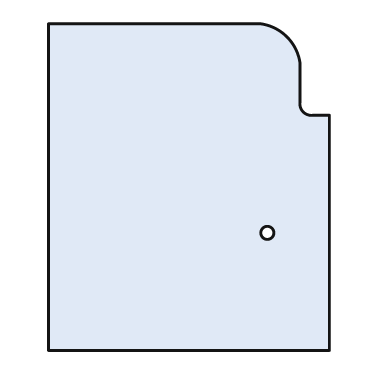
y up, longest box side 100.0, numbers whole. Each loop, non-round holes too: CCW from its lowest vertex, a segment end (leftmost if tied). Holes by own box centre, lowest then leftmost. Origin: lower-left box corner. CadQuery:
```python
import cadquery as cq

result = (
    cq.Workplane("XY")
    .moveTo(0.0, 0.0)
    .lineTo(86.0, 0.0)
    .lineTo(86.0, 72.0)
    .lineTo(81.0, 72.0)
    .threePointArc((78.0, 73.0), (77.0, 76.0))
    .lineTo(77.0, 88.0)
    .threePointArc((73.0, 96.0), (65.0, 100.0))
    .lineTo(0.0, 100.0)
    .close()
    .moveTo(67.0, 36.0)
    .circle(2.0)
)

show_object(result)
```